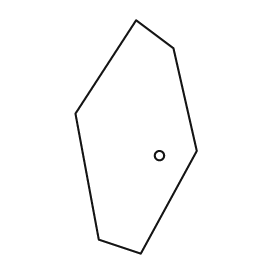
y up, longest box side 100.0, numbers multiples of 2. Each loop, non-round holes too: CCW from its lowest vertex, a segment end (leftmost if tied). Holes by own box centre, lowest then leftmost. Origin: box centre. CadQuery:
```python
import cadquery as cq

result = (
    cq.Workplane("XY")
    .moveTo(2.0, -50.0)
    .lineTo(26.0, -6.0)
    .lineTo(16.0, 38.0)
    .lineTo(0.0, 50.0)
    .lineTo(-26.0, 10.0)
    .lineTo(-16.0, -44.0)
    .close()
    .moveTo(10.0, -8.0)
    .circle(2.0)
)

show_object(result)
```